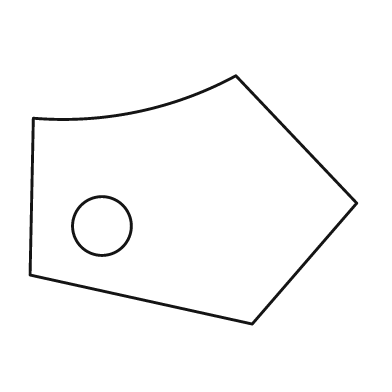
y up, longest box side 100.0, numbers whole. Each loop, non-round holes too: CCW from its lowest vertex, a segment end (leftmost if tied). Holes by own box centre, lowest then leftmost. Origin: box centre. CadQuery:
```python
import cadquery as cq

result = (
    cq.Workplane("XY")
    .moveTo(18.0, -38.0)
    .lineTo(50.0, -1.0)
    .lineTo(13.0, 38.0)
    .threePointArc((-17.0, 27.0), (-49.0, 25.0))
    .lineTo(-50.0, -23.0)
    .close()
    .moveTo(-28.0, -8.0)
    .circle(9.0)
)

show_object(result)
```